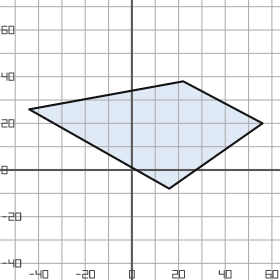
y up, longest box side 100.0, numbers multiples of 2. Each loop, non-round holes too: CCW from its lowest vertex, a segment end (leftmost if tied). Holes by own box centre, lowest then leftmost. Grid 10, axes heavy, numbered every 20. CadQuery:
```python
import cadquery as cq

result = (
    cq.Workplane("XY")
    .moveTo(16.0, -8.0)
    .lineTo(56.0, 20.0)
    .lineTo(22.0, 38.0)
    .lineTo(-44.0, 26.0)
    .close()
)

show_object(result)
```